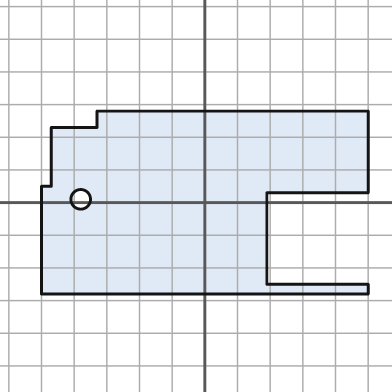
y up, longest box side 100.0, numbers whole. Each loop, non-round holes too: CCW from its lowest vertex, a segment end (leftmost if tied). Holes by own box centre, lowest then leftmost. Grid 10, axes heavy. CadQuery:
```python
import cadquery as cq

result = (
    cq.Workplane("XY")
    .moveTo(-50.0, -28.0)
    .lineTo(50.0, -28.0)
    .lineTo(50.0, -25.0)
    .lineTo(19.0, -25.0)
    .lineTo(19.0, 3.0)
    .lineTo(50.0, 3.0)
    .lineTo(50.0, 28.0)
    .lineTo(-33.0, 28.0)
    .lineTo(-33.0, 23.0)
    .lineTo(-47.0, 23.0)
    .lineTo(-47.0, 5.0)
    .lineTo(-50.0, 5.0)
    .close()
    .moveTo(-38.0, 1.0)
    .circle(3.0)
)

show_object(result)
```